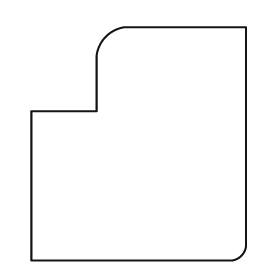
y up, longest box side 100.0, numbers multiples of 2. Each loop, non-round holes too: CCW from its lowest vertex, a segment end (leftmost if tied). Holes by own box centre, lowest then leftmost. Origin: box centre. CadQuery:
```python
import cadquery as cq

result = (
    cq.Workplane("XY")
    .moveTo(-46.0, -50.0)
    .lineTo(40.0, -50.0)
    .threePointArc((44.0, -48.0), (46.0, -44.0))
    .lineTo(46.0, 50.0)
    .lineTo(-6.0, 50.0)
    .threePointArc((-14.0, 46.0), (-18.0, 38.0))
    .lineTo(-18.0, 14.0)
    .lineTo(-46.0, 14.0)
    .close()
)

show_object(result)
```